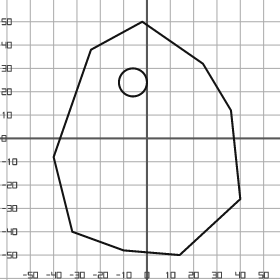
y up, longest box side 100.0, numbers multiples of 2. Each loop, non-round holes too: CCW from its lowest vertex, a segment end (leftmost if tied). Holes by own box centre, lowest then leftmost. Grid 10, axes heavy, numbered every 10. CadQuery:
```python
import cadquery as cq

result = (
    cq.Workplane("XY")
    .moveTo(14.0, -50.0)
    .lineTo(40.0, -26.0)
    .lineTo(36.0, 12.0)
    .lineTo(24.0, 32.0)
    .lineTo(-2.0, 50.0)
    .lineTo(-24.0, 38.0)
    .lineTo(-40.0, -8.0)
    .lineTo(-32.0, -40.0)
    .lineTo(-10.0, -48.0)
    .close()
    .moveTo(-6.0, 24.0)
    .circle(6.0)
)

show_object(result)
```